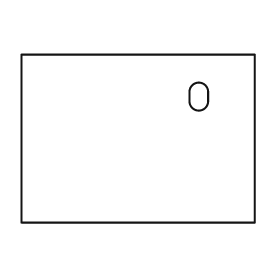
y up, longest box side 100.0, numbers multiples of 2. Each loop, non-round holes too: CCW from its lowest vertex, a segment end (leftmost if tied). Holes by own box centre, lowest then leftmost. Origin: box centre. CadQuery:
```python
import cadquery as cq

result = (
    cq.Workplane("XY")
    .moveTo(-50.0, -36.0)
    .lineTo(50.0, -36.0)
    .lineTo(50.0, 36.0)
    .lineTo(-50.0, 36.0)
    .close()
    .moveTo(22.0, 16.0)
    .threePointArc((26.0, 12.0), (30.0, 16.0))
    .lineTo(30.0, 20.0)
    .threePointArc((26.0, 24.0), (22.0, 20.0))
    .close()
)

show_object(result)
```